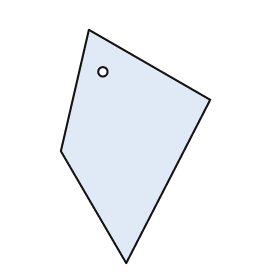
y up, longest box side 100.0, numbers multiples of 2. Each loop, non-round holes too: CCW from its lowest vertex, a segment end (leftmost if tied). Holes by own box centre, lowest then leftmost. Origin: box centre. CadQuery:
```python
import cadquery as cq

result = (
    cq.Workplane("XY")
    .moveTo(-4.0, -50.0)
    .lineTo(32.0, 20.0)
    .lineTo(-20.0, 50.0)
    .lineTo(-32.0, -2.0)
    .close()
    .moveTo(-14.0, 32.0)
    .circle(2.0)
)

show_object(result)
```